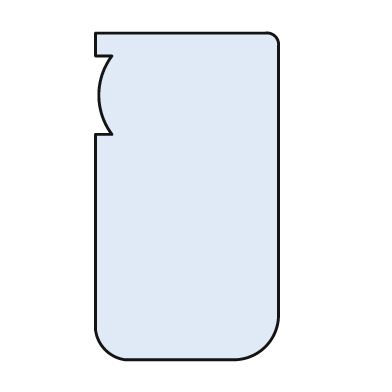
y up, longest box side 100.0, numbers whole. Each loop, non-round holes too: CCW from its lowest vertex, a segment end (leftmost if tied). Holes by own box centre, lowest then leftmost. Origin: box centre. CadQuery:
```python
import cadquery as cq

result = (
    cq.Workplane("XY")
    .moveTo(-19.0, -50.0)
    .lineTo(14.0, -50.0)
    .threePointArc((24.0, -46.0), (28.0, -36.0))
    .lineTo(28.0, 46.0)
    .threePointArc((27.0, 49.0), (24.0, 50.0))
    .lineTo(-28.0, 50.0)
    .lineTo(-28.0, 43.0)
    .lineTo(-23.0, 43.0)
    .threePointArc((-27.0, 31.0), (-23.0, 19.0))
    .lineTo(-28.0, 19.0)
    .lineTo(-28.0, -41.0)
    .threePointArc((-25.0, -47.0), (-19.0, -50.0))
    .close()
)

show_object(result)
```